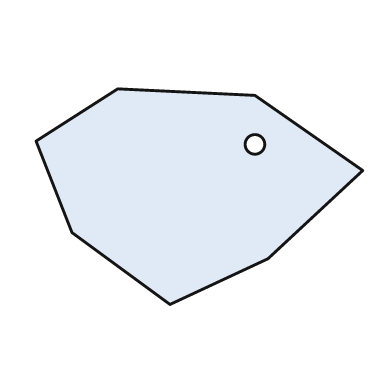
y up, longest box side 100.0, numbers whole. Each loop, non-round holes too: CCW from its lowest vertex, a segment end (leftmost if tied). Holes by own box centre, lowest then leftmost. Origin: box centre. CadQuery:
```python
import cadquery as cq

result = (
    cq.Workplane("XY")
    .moveTo(-9.0, -33.0)
    .lineTo(21.0, -19.0)
    .lineTo(50.0, 8.0)
    .lineTo(17.0, 31.0)
    .lineTo(-25.0, 33.0)
    .lineTo(-50.0, 17.0)
    .lineTo(-39.0, -11.0)
    .close()
    .moveTo(17.0, 16.0)
    .circle(3.0)
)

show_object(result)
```